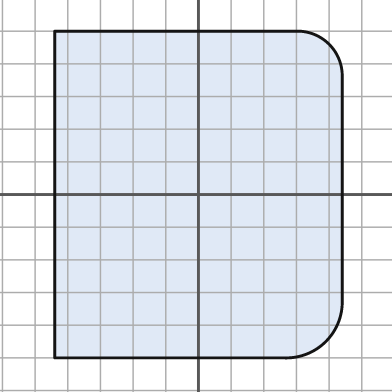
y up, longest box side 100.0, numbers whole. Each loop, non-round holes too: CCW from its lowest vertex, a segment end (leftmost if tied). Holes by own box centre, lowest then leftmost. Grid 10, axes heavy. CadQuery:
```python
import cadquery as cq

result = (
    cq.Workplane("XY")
    .moveTo(-44.0, -50.0)
    .lineTo(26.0, -50.0)
    .threePointArc((39.0, -45.0), (44.0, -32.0))
    .lineTo(44.0, 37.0)
    .threePointArc((40.0, 46.0), (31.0, 50.0))
    .lineTo(-44.0, 50.0)
    .close()
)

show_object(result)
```